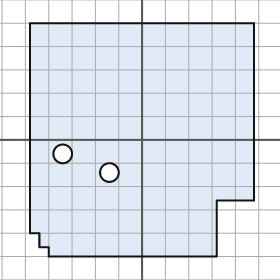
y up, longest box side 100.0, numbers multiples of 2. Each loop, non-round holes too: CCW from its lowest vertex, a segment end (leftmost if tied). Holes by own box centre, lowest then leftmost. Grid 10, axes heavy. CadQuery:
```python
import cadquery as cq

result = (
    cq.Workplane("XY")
    .moveTo(-40.0, -50.0)
    .lineTo(32.0, -50.0)
    .lineTo(32.0, -26.0)
    .lineTo(48.0, -26.0)
    .lineTo(48.0, 50.0)
    .lineTo(-48.0, 50.0)
    .lineTo(-48.0, -40.0)
    .lineTo(-44.0, -40.0)
    .lineTo(-44.0, -46.0)
    .lineTo(-40.0, -46.0)
    .close()
    .moveTo(-14.0, -14.0)
    .circle(4.0)
    .moveTo(-34.0, -6.0)
    .circle(4.0)
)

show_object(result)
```